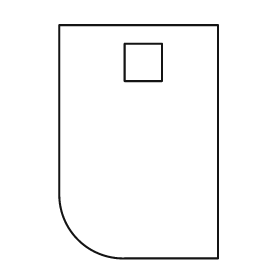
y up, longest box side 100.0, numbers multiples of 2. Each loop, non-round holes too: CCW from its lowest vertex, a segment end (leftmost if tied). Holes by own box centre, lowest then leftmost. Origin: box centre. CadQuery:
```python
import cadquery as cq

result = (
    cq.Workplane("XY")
    .moveTo(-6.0, -50.0)
    .lineTo(34.0, -50.0)
    .lineTo(34.0, 50.0)
    .lineTo(-34.0, 50.0)
    .lineTo(-34.0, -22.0)
    .threePointArc((-26.0, -42.0), (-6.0, -50.0))
    .close()
    .moveTo(-6.0, 26.0)
    .lineTo(10.0, 26.0)
    .lineTo(10.0, 42.0)
    .lineTo(-6.0, 42.0)
    .close()
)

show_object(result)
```